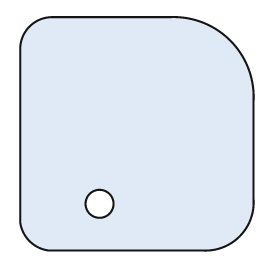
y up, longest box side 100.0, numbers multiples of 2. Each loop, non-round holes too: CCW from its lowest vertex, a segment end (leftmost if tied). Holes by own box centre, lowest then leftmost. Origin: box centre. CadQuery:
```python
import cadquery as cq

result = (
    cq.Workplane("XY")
    .moveTo(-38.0, -50.0)
    .lineTo(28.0, -50.0)
    .threePointArc((44.0, -44.0), (50.0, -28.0))
    .lineTo(50.0, 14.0)
    .threePointArc((40.0, 40.0), (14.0, 50.0))
    .lineTo(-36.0, 50.0)
    .threePointArc((-46.0, 46.0), (-50.0, 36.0))
    .lineTo(-50.0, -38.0)
    .threePointArc((-46.0, -46.0), (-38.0, -50.0))
    .close()
    .moveTo(-16.0, -30.0)
    .circle(6.0)
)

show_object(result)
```